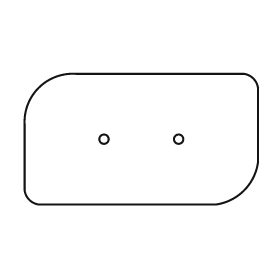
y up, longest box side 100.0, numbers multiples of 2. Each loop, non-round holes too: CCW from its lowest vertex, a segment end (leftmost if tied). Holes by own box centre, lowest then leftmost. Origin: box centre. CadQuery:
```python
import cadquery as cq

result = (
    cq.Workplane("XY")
    .moveTo(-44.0, -28.0)
    .lineTo(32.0, -28.0)
    .threePointArc((44.0, -22.0), (50.0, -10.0))
    .lineTo(50.0, 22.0)
    .threePointArc((48.0, 26.0), (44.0, 28.0))
    .lineTo(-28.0, 28.0)
    .threePointArc((-44.0, 22.0), (-50.0, 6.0))
    .lineTo(-50.0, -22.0)
    .threePointArc((-48.0, -26.0), (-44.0, -28.0))
    .close()
    .moveTo(-16.0, 0.0)
    .circle(2.0)
    .moveTo(16.0, 0.0)
    .circle(2.0)
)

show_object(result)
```